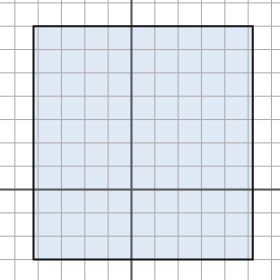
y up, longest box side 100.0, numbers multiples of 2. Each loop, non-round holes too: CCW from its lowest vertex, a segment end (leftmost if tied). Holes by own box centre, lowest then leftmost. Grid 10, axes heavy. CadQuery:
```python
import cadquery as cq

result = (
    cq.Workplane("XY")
    .moveTo(-42.0, -30.0)
    .lineTo(52.0, -30.0)
    .lineTo(52.0, 70.0)
    .lineTo(-42.0, 70.0)
    .close()
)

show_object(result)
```